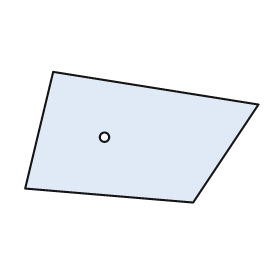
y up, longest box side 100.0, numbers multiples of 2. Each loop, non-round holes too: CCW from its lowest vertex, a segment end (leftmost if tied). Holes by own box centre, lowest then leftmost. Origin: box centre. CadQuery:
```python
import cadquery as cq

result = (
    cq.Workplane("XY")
    .moveTo(22.0, -28.0)
    .lineTo(50.0, 14.0)
    .lineTo(-38.0, 28.0)
    .lineTo(-50.0, -22.0)
    .close()
    .moveTo(-16.0, 0.0)
    .circle(2.0)
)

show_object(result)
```